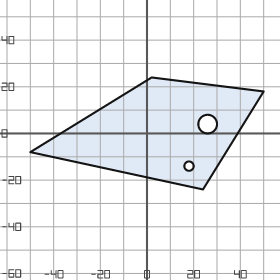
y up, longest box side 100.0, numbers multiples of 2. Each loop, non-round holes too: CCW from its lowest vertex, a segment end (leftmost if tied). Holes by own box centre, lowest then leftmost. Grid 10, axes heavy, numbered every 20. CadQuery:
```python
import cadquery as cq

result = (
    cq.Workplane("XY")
    .moveTo(24.0, -24.0)
    .lineTo(50.0, 18.0)
    .lineTo(2.0, 24.0)
    .lineTo(-50.0, -8.0)
    .close()
    .moveTo(18.0, -14.0)
    .circle(2.0)
    .moveTo(26.0, 4.0)
    .circle(4.0)
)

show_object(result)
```